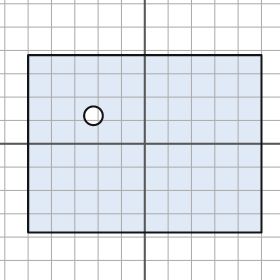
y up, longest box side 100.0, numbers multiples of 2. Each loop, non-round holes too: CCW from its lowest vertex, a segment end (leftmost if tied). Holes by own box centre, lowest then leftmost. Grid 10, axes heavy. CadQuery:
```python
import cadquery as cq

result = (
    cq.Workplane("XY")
    .moveTo(-50.0, -38.0)
    .lineTo(50.0, -38.0)
    .lineTo(50.0, 38.0)
    .lineTo(-50.0, 38.0)
    .close()
    .moveTo(-22.0, 12.0)
    .circle(4.0)
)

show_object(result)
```